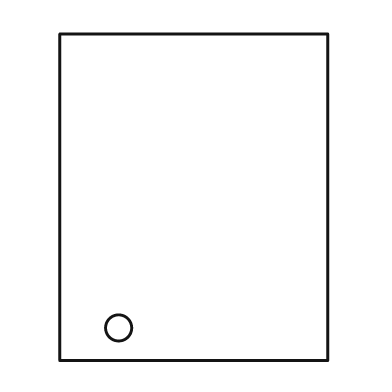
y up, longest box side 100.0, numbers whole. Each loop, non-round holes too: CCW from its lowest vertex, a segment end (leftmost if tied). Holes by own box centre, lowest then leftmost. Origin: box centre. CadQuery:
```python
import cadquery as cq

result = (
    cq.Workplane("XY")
    .moveTo(-41.0, -50.0)
    .lineTo(41.0, -50.0)
    .lineTo(41.0, 50.0)
    .lineTo(-41.0, 50.0)
    .close()
    .moveTo(-23.0, -40.0)
    .circle(4.0)
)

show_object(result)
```